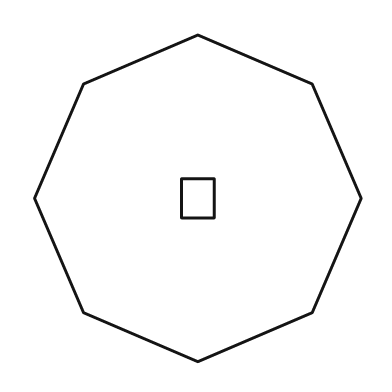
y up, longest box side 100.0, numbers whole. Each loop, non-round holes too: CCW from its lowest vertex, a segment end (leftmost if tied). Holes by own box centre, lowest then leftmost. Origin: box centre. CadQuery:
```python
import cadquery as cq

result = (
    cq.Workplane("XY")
    .moveTo(0.0, -50.0)
    .lineTo(35.0, -35.0)
    .lineTo(50.0, 0.0)
    .lineTo(35.0, 35.0)
    .lineTo(0.0, 50.0)
    .lineTo(-35.0, 35.0)
    .lineTo(-50.0, 0.0)
    .lineTo(-35.0, -35.0)
    .close()
    .moveTo(-5.0, -6.0)
    .lineTo(5.0, -6.0)
    .lineTo(5.0, 6.0)
    .lineTo(-5.0, 6.0)
    .close()
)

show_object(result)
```